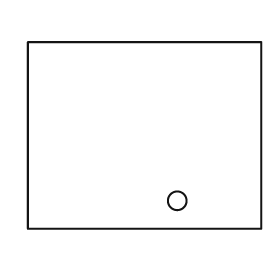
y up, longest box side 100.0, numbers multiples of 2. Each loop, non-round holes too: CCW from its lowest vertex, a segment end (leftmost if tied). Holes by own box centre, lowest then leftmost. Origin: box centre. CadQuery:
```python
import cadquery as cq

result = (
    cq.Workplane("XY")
    .moveTo(-50.0, -40.0)
    .lineTo(50.0, -40.0)
    .lineTo(50.0, 40.0)
    .lineTo(-50.0, 40.0)
    .close()
    .moveTo(14.0, -28.0)
    .circle(4.0)
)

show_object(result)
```